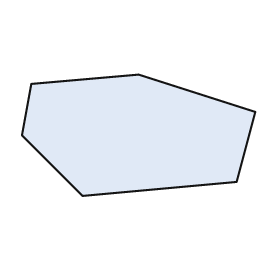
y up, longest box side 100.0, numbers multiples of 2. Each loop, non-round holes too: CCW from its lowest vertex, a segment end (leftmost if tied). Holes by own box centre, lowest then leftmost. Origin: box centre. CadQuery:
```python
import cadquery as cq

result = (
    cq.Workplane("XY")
    .moveTo(-24.0, -26.0)
    .lineTo(42.0, -20.0)
    .lineTo(50.0, 10.0)
    .lineTo(0.0, 26.0)
    .lineTo(-46.0, 22.0)
    .lineTo(-50.0, 0.0)
    .close()
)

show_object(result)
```